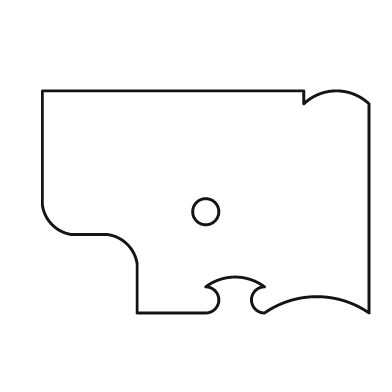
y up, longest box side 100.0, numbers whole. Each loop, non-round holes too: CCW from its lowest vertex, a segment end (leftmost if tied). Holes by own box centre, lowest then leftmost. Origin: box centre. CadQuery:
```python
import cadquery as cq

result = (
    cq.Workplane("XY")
    .moveTo(-21.0, -34.0)
    .lineTo(0.0, -34.0)
    .threePointArc((4.0, -30.0), (0.0, -26.0))
    .threePointArc((9.0, -23.0), (18.0, -26.0))
    .threePointArc((14.0, -30.0), (18.0, -34.0))
    .threePointArc((34.0, -29.0), (50.0, -34.0))
    .lineTo(50.0, 30.0)
    .threePointArc((40.0, 34.0), (30.0, 30.0))
    .lineTo(30.0, 34.0)
    .lineTo(-50.0, 34.0)
    .lineTo(-50.0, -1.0)
    .threePointArc((-47.0, -7.0), (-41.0, -10.0))
    .lineTo(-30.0, -10.0)
    .threePointArc((-24.0, -13.0), (-21.0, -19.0))
    .close()
    .moveTo(0.0, -3.0)
    .circle(4.0)
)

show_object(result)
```